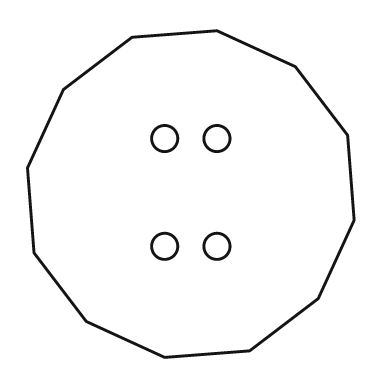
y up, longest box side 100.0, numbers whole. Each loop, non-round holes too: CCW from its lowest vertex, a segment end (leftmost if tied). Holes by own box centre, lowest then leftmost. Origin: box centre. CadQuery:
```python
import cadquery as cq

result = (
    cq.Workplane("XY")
    .moveTo(-8.0, -50.0)
    .lineTo(18.0, -48.0)
    .lineTo(39.0, -32.0)
    .lineTo(50.0, -8.0)
    .lineTo(48.0, 18.0)
    .lineTo(32.0, 39.0)
    .lineTo(8.0, 50.0)
    .lineTo(-18.0, 48.0)
    .lineTo(-39.0, 32.0)
    .lineTo(-50.0, 8.0)
    .lineTo(-48.0, -18.0)
    .lineTo(-32.0, -39.0)
    .close()
    .moveTo(-8.0, -16.0)
    .circle(4.0)
    .moveTo(8.0, -16.0)
    .circle(4.0)
    .moveTo(-8.0, 17.0)
    .circle(4.0)
    .moveTo(8.0, 17.0)
    .circle(4.0)
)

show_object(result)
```